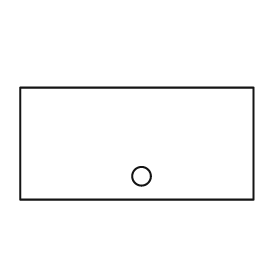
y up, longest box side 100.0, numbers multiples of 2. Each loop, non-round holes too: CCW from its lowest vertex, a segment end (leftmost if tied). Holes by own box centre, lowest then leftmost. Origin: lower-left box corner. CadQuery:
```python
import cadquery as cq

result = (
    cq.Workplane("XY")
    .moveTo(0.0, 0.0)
    .lineTo(100.0, 0.0)
    .lineTo(100.0, 48.0)
    .lineTo(0.0, 48.0)
    .close()
    .moveTo(52.0, 10.0)
    .circle(4.0)
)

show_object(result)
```